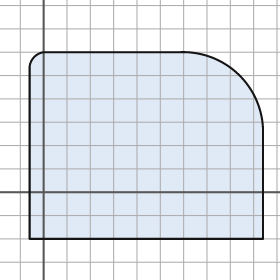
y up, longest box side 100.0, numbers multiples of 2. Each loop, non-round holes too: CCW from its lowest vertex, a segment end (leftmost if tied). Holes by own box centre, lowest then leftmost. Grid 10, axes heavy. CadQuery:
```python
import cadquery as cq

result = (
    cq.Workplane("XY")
    .moveTo(-6.0, -20.0)
    .lineTo(94.0, -20.0)
    .lineTo(94.0, 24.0)
    .threePointArc((84.0, 50.0), (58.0, 60.0))
    .lineTo(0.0, 60.0)
    .threePointArc((-4.0, 58.0), (-6.0, 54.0))
    .close()
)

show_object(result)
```